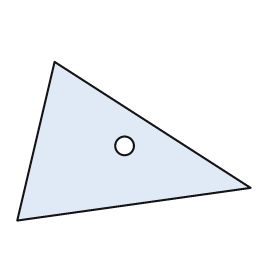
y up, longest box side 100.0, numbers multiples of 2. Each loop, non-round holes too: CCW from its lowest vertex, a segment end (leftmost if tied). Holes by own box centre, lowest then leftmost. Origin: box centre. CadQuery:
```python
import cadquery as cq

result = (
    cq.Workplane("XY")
    .moveTo(-50.0, -34.0)
    .lineTo(50.0, -20.0)
    .lineTo(-34.0, 34.0)
    .close()
    .moveTo(-4.0, -2.0)
    .circle(4.0)
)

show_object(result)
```